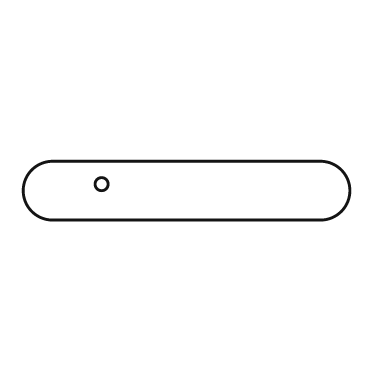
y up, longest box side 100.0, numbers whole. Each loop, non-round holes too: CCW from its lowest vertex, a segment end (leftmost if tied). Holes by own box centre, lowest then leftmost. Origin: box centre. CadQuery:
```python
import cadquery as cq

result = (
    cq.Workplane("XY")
    .moveTo(-41.0, -9.0)
    .lineTo(41.0, -9.0)
    .threePointArc((50.0, 0.0), (41.0, 9.0))
    .lineTo(-41.0, 9.0)
    .threePointArc((-50.0, 0.0), (-41.0, -9.0))
    .close()
    .moveTo(-26.0, 2.0)
    .circle(2.0)
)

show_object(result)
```